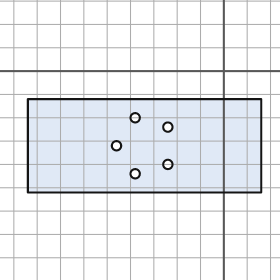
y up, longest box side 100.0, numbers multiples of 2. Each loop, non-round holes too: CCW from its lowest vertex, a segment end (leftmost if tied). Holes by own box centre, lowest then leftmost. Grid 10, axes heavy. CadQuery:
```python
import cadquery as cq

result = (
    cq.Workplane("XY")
    .moveTo(-84.0, -52.0)
    .lineTo(16.0, -52.0)
    .lineTo(16.0, -12.0)
    .lineTo(-84.0, -12.0)
    .close()
    .moveTo(-38.0, -44.0)
    .circle(2.0)
    .moveTo(-24.0, -40.0)
    .circle(2.0)
    .moveTo(-46.0, -32.0)
    .circle(2.0)
    .moveTo(-24.0, -24.0)
    .circle(2.0)
    .moveTo(-38.0, -20.0)
    .circle(2.0)
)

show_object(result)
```